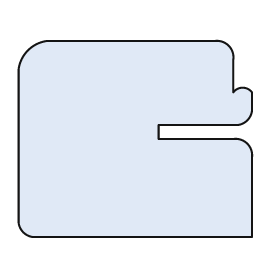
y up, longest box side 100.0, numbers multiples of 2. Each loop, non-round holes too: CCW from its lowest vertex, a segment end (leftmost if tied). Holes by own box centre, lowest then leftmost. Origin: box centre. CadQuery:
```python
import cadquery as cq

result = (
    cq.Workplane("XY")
    .moveTo(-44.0, -42.0)
    .lineTo(50.0, -42.0)
    .lineTo(50.0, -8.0)
    .threePointArc((48.0, -2.0), (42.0, 0.0))
    .lineTo(10.0, 0.0)
    .lineTo(10.0, 6.0)
    .lineTo(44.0, 6.0)
    .threePointArc((48.0, 8.0), (50.0, 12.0))
    .lineTo(50.0, 20.0)
    .threePointArc((46.0, 22.0), (42.0, 20.0))
    .lineTo(42.0, 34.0)
    .threePointArc((40.0, 40.0), (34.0, 42.0))
    .lineTo(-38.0, 42.0)
    .threePointArc((-46.0, 38.0), (-50.0, 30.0))
    .lineTo(-50.0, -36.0)
    .threePointArc((-48.0, -40.0), (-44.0, -42.0))
    .close()
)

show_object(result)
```